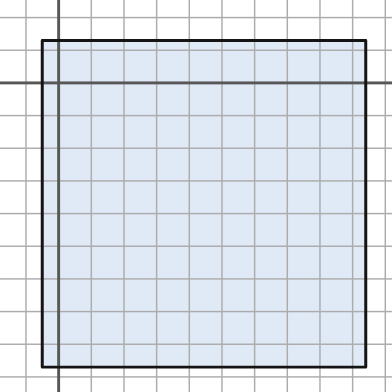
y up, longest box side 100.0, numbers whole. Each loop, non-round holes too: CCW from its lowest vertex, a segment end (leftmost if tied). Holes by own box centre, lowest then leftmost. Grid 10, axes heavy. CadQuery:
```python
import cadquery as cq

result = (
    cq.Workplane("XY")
    .moveTo(-5.0, -87.0)
    .lineTo(94.0, -87.0)
    .lineTo(94.0, 13.0)
    .lineTo(-5.0, 13.0)
    .close()
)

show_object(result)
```